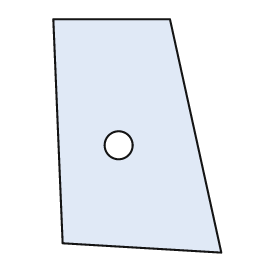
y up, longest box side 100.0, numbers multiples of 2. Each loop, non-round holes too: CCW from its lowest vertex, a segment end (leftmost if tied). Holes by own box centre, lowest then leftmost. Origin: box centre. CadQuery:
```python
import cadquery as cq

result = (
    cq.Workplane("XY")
    .moveTo(36.0, -50.0)
    .lineTo(14.0, 50.0)
    .lineTo(-36.0, 50.0)
    .lineTo(-32.0, -46.0)
    .close()
    .moveTo(-8.0, -4.0)
    .circle(6.0)
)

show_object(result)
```